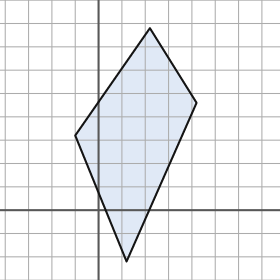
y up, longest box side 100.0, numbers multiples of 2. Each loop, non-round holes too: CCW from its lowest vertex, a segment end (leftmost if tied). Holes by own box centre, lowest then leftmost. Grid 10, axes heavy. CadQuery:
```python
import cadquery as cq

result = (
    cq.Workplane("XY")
    .moveTo(12.0, -22.0)
    .lineTo(42.0, 46.0)
    .lineTo(22.0, 78.0)
    .lineTo(-10.0, 32.0)
    .close()
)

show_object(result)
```